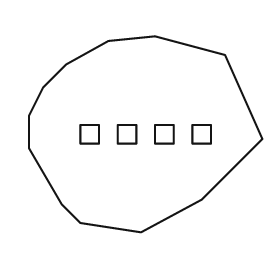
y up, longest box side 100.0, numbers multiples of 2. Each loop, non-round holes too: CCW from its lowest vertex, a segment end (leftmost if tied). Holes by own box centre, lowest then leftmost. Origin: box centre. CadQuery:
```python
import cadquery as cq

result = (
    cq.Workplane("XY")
    .moveTo(-2.0, -42.0)
    .lineTo(24.0, -28.0)
    .lineTo(50.0, -2.0)
    .lineTo(34.0, 34.0)
    .lineTo(4.0, 42.0)
    .lineTo(-16.0, 40.0)
    .lineTo(-34.0, 30.0)
    .lineTo(-44.0, 20.0)
    .lineTo(-50.0, 8.0)
    .lineTo(-50.0, -6.0)
    .lineTo(-36.0, -30.0)
    .lineTo(-28.0, -38.0)
    .close()
    .moveTo(-28.0, -4.0)
    .lineTo(-20.0, -4.0)
    .lineTo(-20.0, 4.0)
    .lineTo(-28.0, 4.0)
    .close()
    .moveTo(-12.0, -4.0)
    .lineTo(-4.0, -4.0)
    .lineTo(-4.0, 4.0)
    .lineTo(-12.0, 4.0)
    .close()
    .moveTo(4.0, -4.0)
    .lineTo(12.0, -4.0)
    .lineTo(12.0, 4.0)
    .lineTo(4.0, 4.0)
    .close()
    .moveTo(20.0, -4.0)
    .lineTo(28.0, -4.0)
    .lineTo(28.0, 4.0)
    .lineTo(20.0, 4.0)
    .close()
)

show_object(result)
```